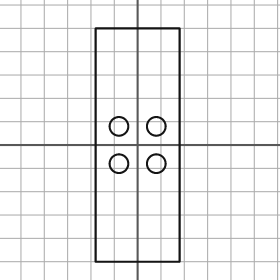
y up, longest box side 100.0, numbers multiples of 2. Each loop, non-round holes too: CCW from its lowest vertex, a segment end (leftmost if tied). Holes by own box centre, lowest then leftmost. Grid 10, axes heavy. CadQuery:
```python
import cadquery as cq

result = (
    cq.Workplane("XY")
    .moveTo(-18.0, -50.0)
    .lineTo(18.0, -50.0)
    .lineTo(18.0, 50.0)
    .lineTo(-18.0, 50.0)
    .close()
    .moveTo(-8.0, -8.0)
    .circle(4.0)
    .moveTo(8.0, -8.0)
    .circle(4.0)
    .moveTo(-8.0, 8.0)
    .circle(4.0)
    .moveTo(8.0, 8.0)
    .circle(4.0)
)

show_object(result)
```